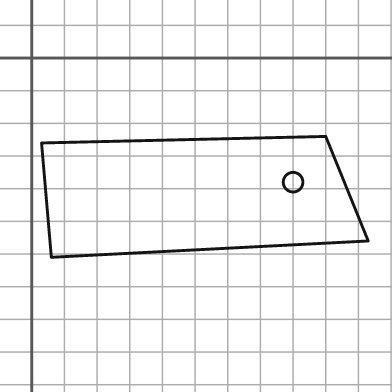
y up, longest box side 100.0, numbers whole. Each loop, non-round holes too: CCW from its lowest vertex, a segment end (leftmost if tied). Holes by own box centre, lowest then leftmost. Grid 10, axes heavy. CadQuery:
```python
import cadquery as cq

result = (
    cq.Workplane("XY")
    .moveTo(6.0, -61.0)
    .lineTo(103.0, -56.0)
    .lineTo(90.0, -24.0)
    .lineTo(3.0, -26.0)
    .close()
    .moveTo(80.0, -38.0)
    .circle(3.0)
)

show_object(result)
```